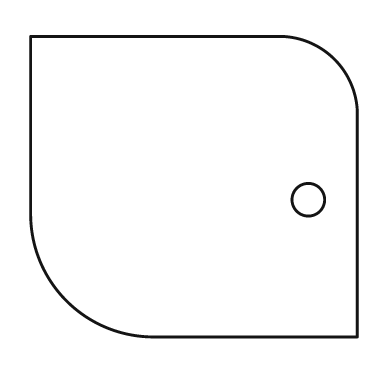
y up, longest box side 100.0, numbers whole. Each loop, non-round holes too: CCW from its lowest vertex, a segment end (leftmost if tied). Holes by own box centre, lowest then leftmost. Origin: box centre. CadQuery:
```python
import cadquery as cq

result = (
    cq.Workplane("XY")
    .moveTo(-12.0, -46.0)
    .lineTo(50.0, -46.0)
    .lineTo(50.0, 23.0)
    .threePointArc((43.0, 39.0), (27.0, 46.0))
    .lineTo(-50.0, 46.0)
    .lineTo(-50.0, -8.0)
    .threePointArc((-39.0, -35.0), (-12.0, -46.0))
    .close()
    .moveTo(35.0, -4.0)
    .circle(5.0)
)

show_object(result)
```